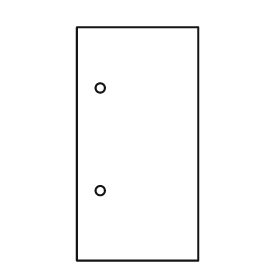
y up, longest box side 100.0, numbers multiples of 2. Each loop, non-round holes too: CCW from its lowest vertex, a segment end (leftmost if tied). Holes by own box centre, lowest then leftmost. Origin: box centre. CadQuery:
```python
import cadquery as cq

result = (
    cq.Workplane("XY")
    .moveTo(-26.0, -50.0)
    .lineTo(26.0, -50.0)
    .lineTo(26.0, 50.0)
    .lineTo(-26.0, 50.0)
    .close()
    .moveTo(-16.0, -20.0)
    .circle(2.0)
    .moveTo(-16.0, 24.0)
    .circle(2.0)
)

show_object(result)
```